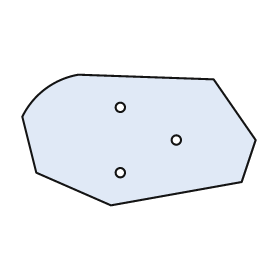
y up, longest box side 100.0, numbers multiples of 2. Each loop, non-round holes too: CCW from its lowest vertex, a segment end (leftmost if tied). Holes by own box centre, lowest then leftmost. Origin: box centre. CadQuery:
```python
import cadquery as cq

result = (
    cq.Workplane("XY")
    .moveTo(-12.0, -28.0)
    .lineTo(44.0, -18.0)
    .lineTo(50.0, 0.0)
    .lineTo(32.0, 26.0)
    .lineTo(-26.0, 28.0)
    .threePointArc((-40.0, 22.0), (-50.0, 10.0))
    .lineTo(-44.0, -14.0)
    .close()
    .moveTo(-8.0, -14.0)
    .circle(2.0)
    .moveTo(16.0, 0.0)
    .circle(2.0)
    .moveTo(-8.0, 14.0)
    .circle(2.0)
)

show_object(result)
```